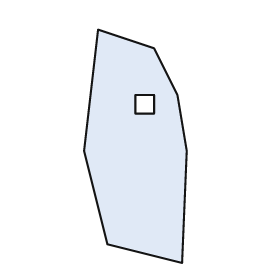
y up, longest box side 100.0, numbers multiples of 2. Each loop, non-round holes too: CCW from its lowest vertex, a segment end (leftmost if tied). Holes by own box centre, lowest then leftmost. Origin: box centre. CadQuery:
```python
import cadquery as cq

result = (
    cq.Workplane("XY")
    .moveTo(20.0, -50.0)
    .lineTo(22.0, -2.0)
    .lineTo(18.0, 22.0)
    .lineTo(8.0, 42.0)
    .lineTo(-16.0, 50.0)
    .lineTo(-22.0, -2.0)
    .lineTo(-12.0, -42.0)
    .close()
    .moveTo(0.0, 14.0)
    .lineTo(8.0, 14.0)
    .lineTo(8.0, 22.0)
    .lineTo(0.0, 22.0)
    .close()
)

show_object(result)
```